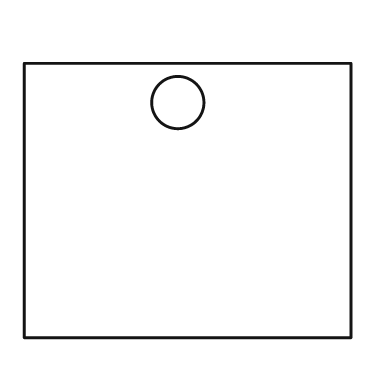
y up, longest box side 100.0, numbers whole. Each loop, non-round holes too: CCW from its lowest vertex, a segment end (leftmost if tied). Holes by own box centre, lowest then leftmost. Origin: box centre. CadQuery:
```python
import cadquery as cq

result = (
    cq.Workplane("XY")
    .moveTo(-50.0, -42.0)
    .lineTo(50.0, -42.0)
    .lineTo(50.0, 42.0)
    .lineTo(-50.0, 42.0)
    .close()
    .moveTo(-3.0, 30.0)
    .circle(8.0)
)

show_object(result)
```